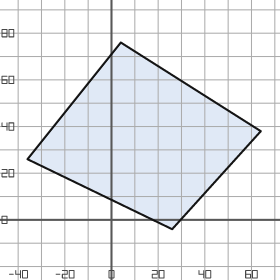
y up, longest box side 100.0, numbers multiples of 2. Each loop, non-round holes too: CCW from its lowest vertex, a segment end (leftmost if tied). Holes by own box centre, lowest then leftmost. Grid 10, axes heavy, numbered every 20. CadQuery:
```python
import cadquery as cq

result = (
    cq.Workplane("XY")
    .moveTo(26.0, -4.0)
    .lineTo(64.0, 38.0)
    .lineTo(4.0, 76.0)
    .lineTo(-36.0, 26.0)
    .close()
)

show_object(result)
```